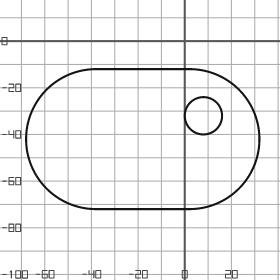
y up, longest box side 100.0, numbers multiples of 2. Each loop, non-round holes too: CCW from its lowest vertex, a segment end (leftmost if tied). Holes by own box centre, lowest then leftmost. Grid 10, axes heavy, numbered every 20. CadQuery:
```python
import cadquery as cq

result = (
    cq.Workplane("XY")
    .moveTo(-38.0, -72.0)
    .lineTo(2.0, -72.0)
    .threePointArc((32.0, -42.0), (2.0, -12.0))
    .lineTo(-38.0, -12.0)
    .threePointArc((-68.0, -42.0), (-38.0, -72.0))
    .close()
    .moveTo(8.0, -32.0)
    .circle(8.0)
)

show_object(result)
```